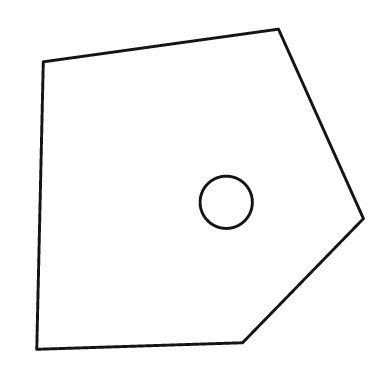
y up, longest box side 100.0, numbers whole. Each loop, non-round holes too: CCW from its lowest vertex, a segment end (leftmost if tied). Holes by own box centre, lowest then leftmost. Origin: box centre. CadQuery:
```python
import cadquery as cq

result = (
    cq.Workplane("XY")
    .moveTo(-50.0, -49.0)
    .lineTo(13.0, -47.0)
    .lineTo(50.0, -9.0)
    .lineTo(24.0, 49.0)
    .lineTo(-48.0, 39.0)
    .close()
    .moveTo(8.0, -4.0)
    .circle(8.0)
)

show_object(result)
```